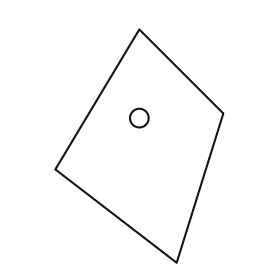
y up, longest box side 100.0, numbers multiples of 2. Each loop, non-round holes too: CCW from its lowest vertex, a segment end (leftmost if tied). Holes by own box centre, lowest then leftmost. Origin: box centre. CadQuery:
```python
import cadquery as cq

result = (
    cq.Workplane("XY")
    .moveTo(16.0, -50.0)
    .lineTo(36.0, 14.0)
    .lineTo(0.0, 50.0)
    .lineTo(-36.0, -10.0)
    .close()
    .moveTo(0.0, 12.0)
    .circle(4.0)
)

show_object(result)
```